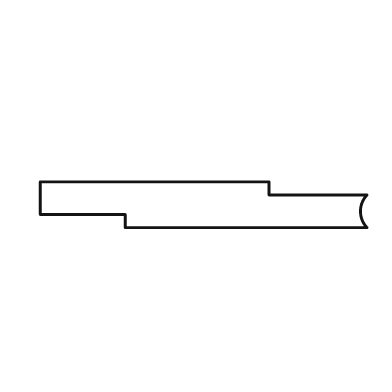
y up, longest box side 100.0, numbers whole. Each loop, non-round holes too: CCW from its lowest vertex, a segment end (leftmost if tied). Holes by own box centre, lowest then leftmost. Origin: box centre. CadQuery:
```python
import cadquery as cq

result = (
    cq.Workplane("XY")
    .moveTo(-24.0, -7.0)
    .lineTo(50.0, -7.0)
    .threePointArc((48.0, -2.0), (50.0, 3.0))
    .lineTo(20.0, 3.0)
    .lineTo(20.0, 7.0)
    .lineTo(-50.0, 7.0)
    .lineTo(-50.0, -3.0)
    .lineTo(-24.0, -3.0)
    .close()
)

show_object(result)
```